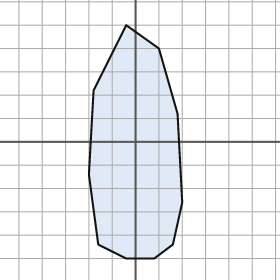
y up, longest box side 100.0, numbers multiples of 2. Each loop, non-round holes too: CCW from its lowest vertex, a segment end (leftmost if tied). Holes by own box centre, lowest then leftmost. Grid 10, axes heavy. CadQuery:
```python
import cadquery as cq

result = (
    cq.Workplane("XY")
    .moveTo(-4.0, -50.0)
    .lineTo(8.0, -50.0)
    .lineTo(16.0, -44.0)
    .lineTo(20.0, -26.0)
    .lineTo(18.0, 12.0)
    .lineTo(10.0, 40.0)
    .lineTo(-4.0, 50.0)
    .lineTo(-18.0, 22.0)
    .lineTo(-20.0, -14.0)
    .lineTo(-16.0, -44.0)
    .close()
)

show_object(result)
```